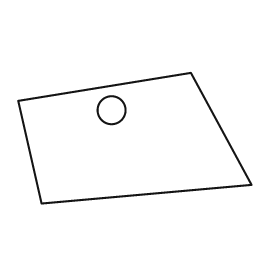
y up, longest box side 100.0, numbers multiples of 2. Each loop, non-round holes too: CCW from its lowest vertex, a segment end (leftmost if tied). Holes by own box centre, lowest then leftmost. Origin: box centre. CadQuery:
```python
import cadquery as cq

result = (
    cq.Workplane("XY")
    .moveTo(-40.0, -28.0)
    .lineTo(50.0, -20.0)
    .lineTo(24.0, 28.0)
    .lineTo(-50.0, 16.0)
    .close()
    .moveTo(-10.0, 12.0)
    .circle(6.0)
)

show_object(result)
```